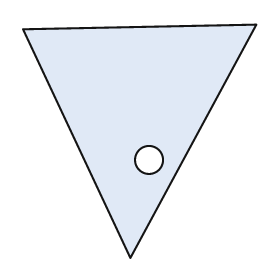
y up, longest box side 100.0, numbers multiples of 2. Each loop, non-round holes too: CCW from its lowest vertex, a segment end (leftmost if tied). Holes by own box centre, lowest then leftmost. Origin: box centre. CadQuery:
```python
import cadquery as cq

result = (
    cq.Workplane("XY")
    .moveTo(-4.0, -50.0)
    .lineTo(50.0, 50.0)
    .lineTo(-50.0, 48.0)
    .close()
    .moveTo(4.0, -8.0)
    .circle(6.0)
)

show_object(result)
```